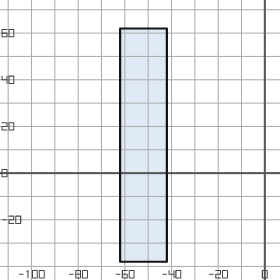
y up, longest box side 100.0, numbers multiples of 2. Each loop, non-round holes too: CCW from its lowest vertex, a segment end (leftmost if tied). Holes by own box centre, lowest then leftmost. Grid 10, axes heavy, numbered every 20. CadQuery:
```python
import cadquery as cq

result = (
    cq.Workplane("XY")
    .moveTo(-62.0, -38.0)
    .lineTo(-42.0, -38.0)
    .lineTo(-42.0, 62.0)
    .lineTo(-62.0, 62.0)
    .close()
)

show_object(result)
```